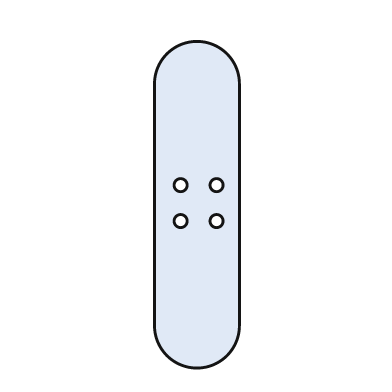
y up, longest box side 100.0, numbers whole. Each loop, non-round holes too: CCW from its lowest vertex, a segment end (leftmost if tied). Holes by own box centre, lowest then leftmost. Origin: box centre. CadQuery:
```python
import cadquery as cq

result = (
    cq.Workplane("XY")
    .moveTo(-13.0, -37.0)
    .threePointArc((0.0, -50.0), (13.0, -37.0))
    .lineTo(13.0, 37.0)
    .threePointArc((0.0, 50.0), (-13.0, 37.0))
    .close()
    .moveTo(-5.0, -5.0)
    .circle(2.0)
    .moveTo(6.0, -5.0)
    .circle(2.0)
    .moveTo(-5.0, 6.0)
    .circle(2.0)
    .moveTo(6.0, 6.0)
    .circle(2.0)
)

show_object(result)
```